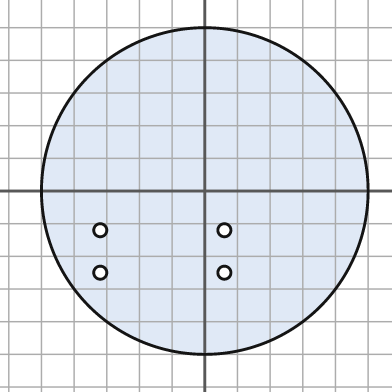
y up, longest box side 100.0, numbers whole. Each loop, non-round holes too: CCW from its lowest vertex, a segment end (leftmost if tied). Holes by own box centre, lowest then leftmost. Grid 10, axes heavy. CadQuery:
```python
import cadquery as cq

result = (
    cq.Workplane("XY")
    .moveTo(0.0, 0.0)
    .circle(50.0)
    .moveTo(-32.0, -25.0)
    .circle(2.0)
    .moveTo(6.0, -25.0)
    .circle(2.0)
    .moveTo(-32.0, -12.0)
    .circle(2.0)
    .moveTo(6.0, -12.0)
    .circle(2.0)
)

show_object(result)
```